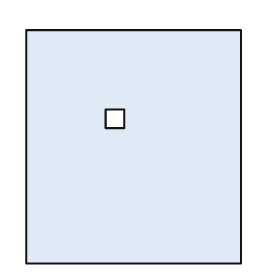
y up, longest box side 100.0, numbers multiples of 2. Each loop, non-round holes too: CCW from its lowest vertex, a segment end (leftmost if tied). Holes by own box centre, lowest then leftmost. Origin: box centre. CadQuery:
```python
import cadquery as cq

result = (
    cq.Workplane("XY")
    .moveTo(-46.0, -50.0)
    .lineTo(46.0, -50.0)
    .lineTo(46.0, 50.0)
    .lineTo(-46.0, 50.0)
    .close()
    .moveTo(-12.0, 8.0)
    .lineTo(-4.0, 8.0)
    .lineTo(-4.0, 16.0)
    .lineTo(-12.0, 16.0)
    .close()
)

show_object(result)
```